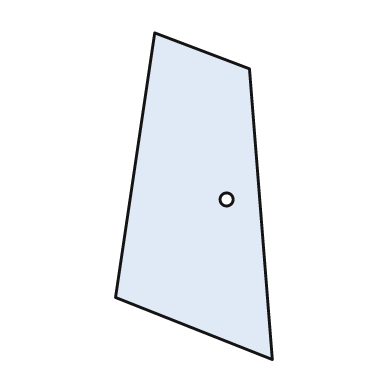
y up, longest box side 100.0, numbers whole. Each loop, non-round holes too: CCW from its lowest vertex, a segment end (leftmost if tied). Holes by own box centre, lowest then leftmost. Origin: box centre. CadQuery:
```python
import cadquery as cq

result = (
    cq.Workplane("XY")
    .moveTo(24.0, -50.0)
    .lineTo(17.0, 39.0)
    .lineTo(-12.0, 50.0)
    .lineTo(-24.0, -31.0)
    .close()
    .moveTo(10.0, -1.0)
    .circle(2.0)
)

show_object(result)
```